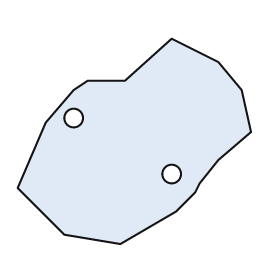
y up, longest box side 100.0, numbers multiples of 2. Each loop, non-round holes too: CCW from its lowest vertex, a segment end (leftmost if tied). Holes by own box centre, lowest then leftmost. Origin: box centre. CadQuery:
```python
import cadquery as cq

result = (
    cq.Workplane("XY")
    .moveTo(-6.0, -44.0)
    .lineTo(18.0, -30.0)
    .lineTo(26.0, -22.0)
    .lineTo(28.0, -18.0)
    .lineTo(36.0, -8.0)
    .lineTo(50.0, 4.0)
    .lineTo(46.0, 22.0)
    .lineTo(36.0, 34.0)
    .lineTo(16.0, 44.0)
    .lineTo(-4.0, 26.0)
    .lineTo(-20.0, 26.0)
    .lineTo(-26.0, 22.0)
    .lineTo(-38.0, 8.0)
    .lineTo(-50.0, -20.0)
    .lineTo(-30.0, -40.0)
    .close()
    .moveTo(16.0, -14.0)
    .circle(4.0)
    .moveTo(-26.0, 10.0)
    .circle(4.0)
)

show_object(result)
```